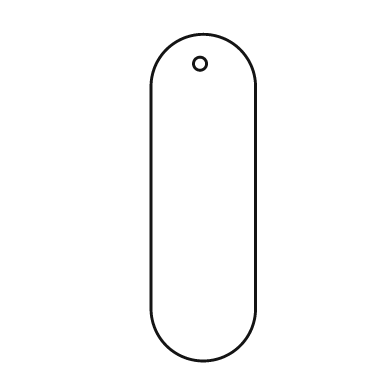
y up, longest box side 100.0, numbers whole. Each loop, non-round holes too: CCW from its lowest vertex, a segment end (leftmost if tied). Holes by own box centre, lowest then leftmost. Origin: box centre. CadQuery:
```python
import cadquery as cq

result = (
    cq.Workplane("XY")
    .moveTo(-16.0, -34.0)
    .threePointArc((0.0, -50.0), (16.0, -34.0))
    .lineTo(16.0, 34.0)
    .threePointArc((0.0, 50.0), (-16.0, 34.0))
    .close()
    .moveTo(-1.0, 41.0)
    .circle(2.0)
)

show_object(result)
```